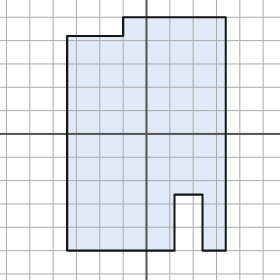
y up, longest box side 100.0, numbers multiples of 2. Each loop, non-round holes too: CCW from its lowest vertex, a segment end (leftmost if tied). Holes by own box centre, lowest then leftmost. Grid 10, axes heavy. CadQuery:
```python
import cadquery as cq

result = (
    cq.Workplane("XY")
    .moveTo(-34.0, -50.0)
    .lineTo(12.0, -50.0)
    .lineTo(12.0, -26.0)
    .lineTo(24.0, -26.0)
    .lineTo(24.0, -50.0)
    .lineTo(34.0, -50.0)
    .lineTo(34.0, 50.0)
    .lineTo(-10.0, 50.0)
    .lineTo(-10.0, 42.0)
    .lineTo(-34.0, 42.0)
    .close()
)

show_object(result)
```